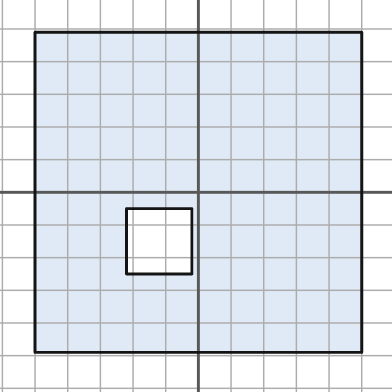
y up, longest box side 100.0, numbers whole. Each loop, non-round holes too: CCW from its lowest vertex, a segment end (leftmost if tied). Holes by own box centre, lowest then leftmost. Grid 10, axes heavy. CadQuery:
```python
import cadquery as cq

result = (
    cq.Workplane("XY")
    .moveTo(-50.0, -49.0)
    .lineTo(50.0, -49.0)
    .lineTo(50.0, 49.0)
    .lineTo(-50.0, 49.0)
    .close()
    .moveTo(-22.0, -25.0)
    .lineTo(-2.0, -25.0)
    .lineTo(-2.0, -5.0)
    .lineTo(-22.0, -5.0)
    .close()
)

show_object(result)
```